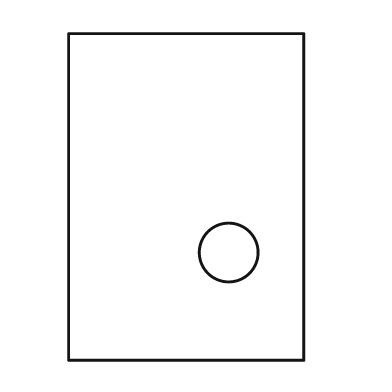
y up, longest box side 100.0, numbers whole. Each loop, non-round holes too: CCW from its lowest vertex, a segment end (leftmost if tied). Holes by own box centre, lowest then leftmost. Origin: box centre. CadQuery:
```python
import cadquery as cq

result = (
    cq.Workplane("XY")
    .moveTo(-36.0, -50.0)
    .lineTo(36.0, -50.0)
    .lineTo(36.0, 50.0)
    .lineTo(-36.0, 50.0)
    .close()
    .moveTo(13.0, -17.0)
    .circle(9.0)
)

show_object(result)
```